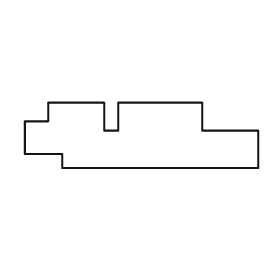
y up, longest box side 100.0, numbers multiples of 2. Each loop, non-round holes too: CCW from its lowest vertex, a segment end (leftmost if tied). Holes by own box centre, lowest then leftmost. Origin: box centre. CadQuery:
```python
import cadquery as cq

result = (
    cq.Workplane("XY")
    .moveTo(-34.0, -14.0)
    .lineTo(50.0, -14.0)
    .lineTo(50.0, 2.0)
    .lineTo(26.0, 2.0)
    .lineTo(26.0, 14.0)
    .lineTo(-10.0, 14.0)
    .lineTo(-10.0, 2.0)
    .lineTo(-16.0, 2.0)
    .lineTo(-16.0, 14.0)
    .lineTo(-40.0, 14.0)
    .lineTo(-40.0, 6.0)
    .lineTo(-50.0, 6.0)
    .lineTo(-50.0, -8.0)
    .lineTo(-34.0, -8.0)
    .close()
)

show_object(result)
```